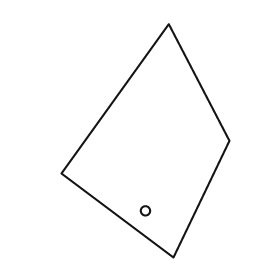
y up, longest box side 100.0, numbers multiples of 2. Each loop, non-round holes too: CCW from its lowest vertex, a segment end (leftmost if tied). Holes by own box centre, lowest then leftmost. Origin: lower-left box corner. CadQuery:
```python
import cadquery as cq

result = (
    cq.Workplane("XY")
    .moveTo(48.0, 0.0)
    .lineTo(72.0, 50.0)
    .lineTo(46.0, 100.0)
    .lineTo(0.0, 36.0)
    .close()
    .moveTo(36.0, 20.0)
    .circle(2.0)
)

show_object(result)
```